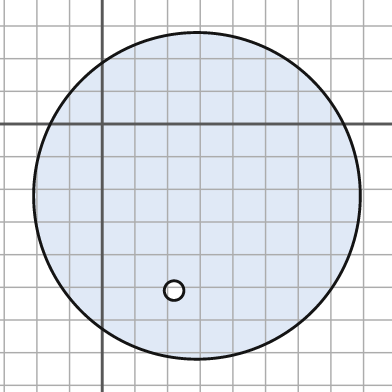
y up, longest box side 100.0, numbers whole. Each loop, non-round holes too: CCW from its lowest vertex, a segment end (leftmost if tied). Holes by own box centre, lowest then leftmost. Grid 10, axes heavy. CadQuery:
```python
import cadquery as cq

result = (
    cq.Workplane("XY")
    .moveTo(29.0, -22.0)
    .circle(50.0)
    .moveTo(22.0, -51.0)
    .circle(3.0)
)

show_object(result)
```